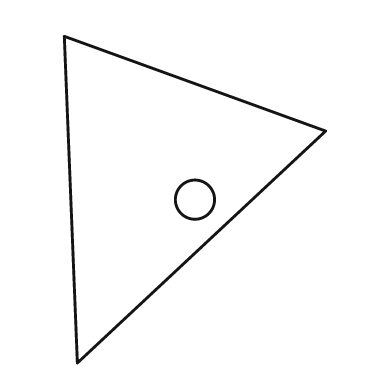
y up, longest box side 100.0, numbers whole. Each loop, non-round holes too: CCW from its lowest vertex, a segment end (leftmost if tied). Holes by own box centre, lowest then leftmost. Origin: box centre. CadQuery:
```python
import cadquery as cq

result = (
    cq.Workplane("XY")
    .moveTo(-36.0, -50.0)
    .lineTo(40.0, 21.0)
    .lineTo(-40.0, 50.0)
    .close()
    .moveTo(0.0, 0.0)
    .circle(6.0)
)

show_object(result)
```